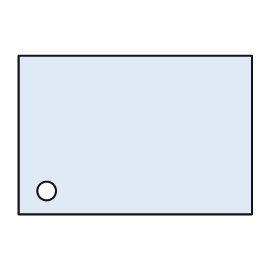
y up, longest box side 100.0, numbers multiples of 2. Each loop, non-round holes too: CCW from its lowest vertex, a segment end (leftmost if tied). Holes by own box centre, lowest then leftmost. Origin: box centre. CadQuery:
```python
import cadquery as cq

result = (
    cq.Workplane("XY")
    .moveTo(-50.0, -34.0)
    .lineTo(50.0, -34.0)
    .lineTo(50.0, 34.0)
    .lineTo(-50.0, 34.0)
    .close()
    .moveTo(-38.0, -24.0)
    .circle(4.0)
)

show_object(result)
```